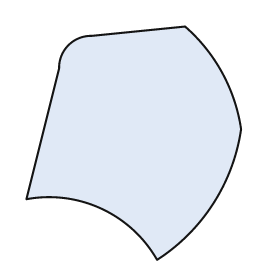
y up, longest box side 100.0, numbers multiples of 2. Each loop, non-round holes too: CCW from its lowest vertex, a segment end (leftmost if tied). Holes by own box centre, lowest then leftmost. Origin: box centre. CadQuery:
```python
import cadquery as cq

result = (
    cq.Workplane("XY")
    .moveTo(10.0, -50.0)
    .threePointArc((34.0, -26.0), (46.0, 6.0))
    .threePointArc((38.0, 30.0), (22.0, 50.0))
    .lineTo(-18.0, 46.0)
    .threePointArc((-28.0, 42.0), (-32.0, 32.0))
    .lineTo(-46.0, -24.0)
    .threePointArc((-14.0, -28.0), (10.0, -50.0))
    .close()
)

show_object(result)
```